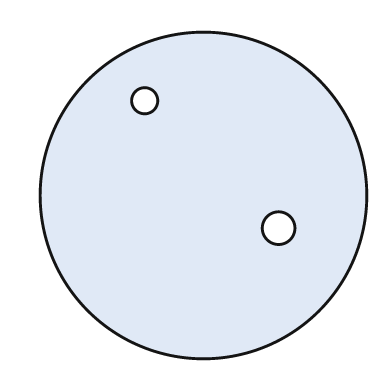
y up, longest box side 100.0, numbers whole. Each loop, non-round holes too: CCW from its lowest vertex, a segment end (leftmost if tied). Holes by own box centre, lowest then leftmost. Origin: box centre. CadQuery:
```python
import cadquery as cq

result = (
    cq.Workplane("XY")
    .moveTo(0.0, 0.0)
    .circle(50.0)
    .moveTo(23.0, -10.0)
    .circle(5.0)
    .moveTo(-18.0, 29.0)
    .circle(4.0)
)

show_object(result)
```